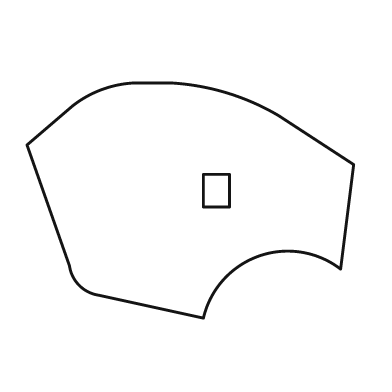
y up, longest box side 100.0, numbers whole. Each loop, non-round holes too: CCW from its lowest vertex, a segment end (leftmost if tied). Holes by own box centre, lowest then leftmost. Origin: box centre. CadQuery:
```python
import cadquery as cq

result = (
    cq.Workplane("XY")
    .moveTo(4.0, -36.0)
    .threePointArc((21.0, -17.0), (46.0, -21.0))
    .lineTo(50.0, 11.0)
    .lineTo(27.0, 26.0)
    .threePointArc((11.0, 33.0), (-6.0, 36.0))
    .lineTo(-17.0, 36.0)
    .threePointArc((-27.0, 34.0), (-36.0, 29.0))
    .lineTo(-50.0, 17.0)
    .lineTo(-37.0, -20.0)
    .threePointArc((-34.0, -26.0), (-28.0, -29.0))
    .close()
    .moveTo(4.0, -2.0)
    .lineTo(12.0, -2.0)
    .lineTo(12.0, 8.0)
    .lineTo(4.0, 8.0)
    .close()
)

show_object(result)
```